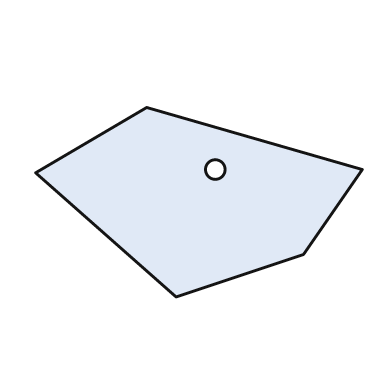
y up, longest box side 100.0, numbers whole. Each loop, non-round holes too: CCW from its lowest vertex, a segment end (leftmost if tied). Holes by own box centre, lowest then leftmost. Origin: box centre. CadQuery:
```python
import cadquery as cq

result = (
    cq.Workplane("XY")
    .moveTo(-7.0, -29.0)
    .lineTo(32.0, -16.0)
    .lineTo(50.0, 10.0)
    .lineTo(-16.0, 29.0)
    .lineTo(-50.0, 9.0)
    .close()
    .moveTo(5.0, 10.0)
    .circle(3.0)
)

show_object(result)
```